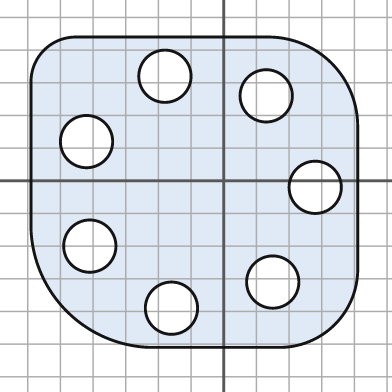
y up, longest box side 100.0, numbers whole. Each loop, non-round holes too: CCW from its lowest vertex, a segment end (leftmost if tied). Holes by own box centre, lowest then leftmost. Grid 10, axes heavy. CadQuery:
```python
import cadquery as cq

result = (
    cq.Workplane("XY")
    .moveTo(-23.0, -51.0)
    .lineTo(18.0, -51.0)
    .threePointArc((34.0, -44.0), (41.0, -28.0))
    .lineTo(41.0, 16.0)
    .threePointArc((33.0, 36.0), (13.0, 44.0))
    .lineTo(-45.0, 44.0)
    .threePointArc((-55.0, 40.0), (-59.0, 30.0))
    .lineTo(-59.0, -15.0)
    .threePointArc((-48.0, -40.0), (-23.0, -51.0))
    .close()
    .moveTo(-16.0, -39.0)
    .circle(8.0)
    .moveTo(15.0, -31.0)
    .circle(8.0)
    .moveTo(-41.0, -20.0)
    .circle(8.0)
    .moveTo(28.0, -2.0)
    .circle(8.0)
    .moveTo(-42.0, 12.0)
    .circle(8.0)
    .moveTo(13.0, 26.0)
    .circle(8.0)
    .moveTo(-18.0, 32.0)
    .circle(8.0)
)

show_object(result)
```